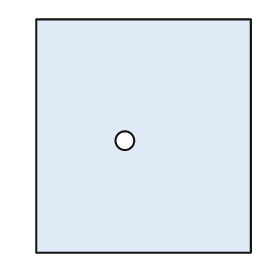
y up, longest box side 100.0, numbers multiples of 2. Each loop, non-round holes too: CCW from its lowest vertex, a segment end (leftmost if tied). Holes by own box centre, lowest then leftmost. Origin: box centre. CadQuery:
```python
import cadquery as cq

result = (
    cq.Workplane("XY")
    .moveTo(-46.0, -50.0)
    .lineTo(46.0, -50.0)
    .lineTo(46.0, 50.0)
    .lineTo(-46.0, 50.0)
    .close()
    .moveTo(-8.0, -2.0)
    .circle(4.0)
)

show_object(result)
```